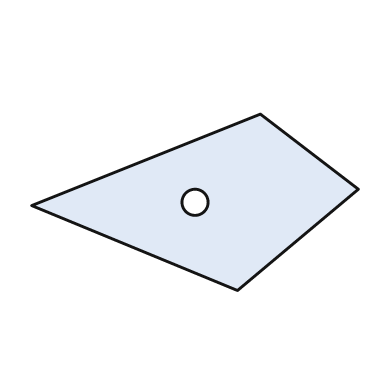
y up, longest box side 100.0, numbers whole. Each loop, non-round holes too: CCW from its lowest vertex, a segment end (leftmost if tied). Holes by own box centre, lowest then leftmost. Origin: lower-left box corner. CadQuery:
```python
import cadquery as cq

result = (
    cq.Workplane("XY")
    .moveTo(63.0, 0.0)
    .lineTo(100.0, 31.0)
    .lineTo(70.0, 54.0)
    .lineTo(0.0, 26.0)
    .close()
    .moveTo(50.0, 27.0)
    .circle(4.0)
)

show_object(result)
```